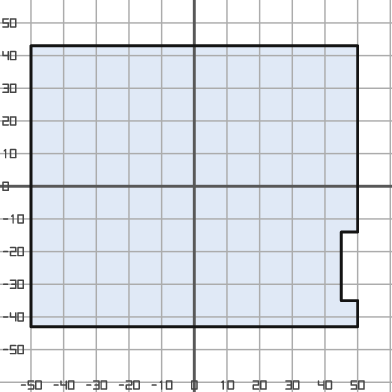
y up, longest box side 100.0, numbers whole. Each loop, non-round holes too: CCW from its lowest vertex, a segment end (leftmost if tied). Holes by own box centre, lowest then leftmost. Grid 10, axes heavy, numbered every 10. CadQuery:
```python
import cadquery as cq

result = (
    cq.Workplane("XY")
    .moveTo(-50.0, -43.0)
    .lineTo(50.0, -43.0)
    .lineTo(50.0, -35.0)
    .lineTo(45.0, -35.0)
    .lineTo(45.0, -14.0)
    .lineTo(50.0, -14.0)
    .lineTo(50.0, 43.0)
    .lineTo(-50.0, 43.0)
    .close()
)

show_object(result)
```